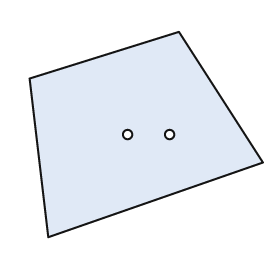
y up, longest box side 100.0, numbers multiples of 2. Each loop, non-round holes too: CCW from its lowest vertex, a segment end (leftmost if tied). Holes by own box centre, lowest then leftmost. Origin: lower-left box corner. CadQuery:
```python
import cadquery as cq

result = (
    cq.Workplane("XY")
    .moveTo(8.0, 0.0)
    .lineTo(100.0, 32.0)
    .lineTo(64.0, 88.0)
    .lineTo(0.0, 68.0)
    .close()
    .moveTo(42.0, 44.0)
    .circle(2.0)
    .moveTo(60.0, 44.0)
    .circle(2.0)
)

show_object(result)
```